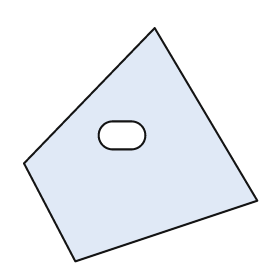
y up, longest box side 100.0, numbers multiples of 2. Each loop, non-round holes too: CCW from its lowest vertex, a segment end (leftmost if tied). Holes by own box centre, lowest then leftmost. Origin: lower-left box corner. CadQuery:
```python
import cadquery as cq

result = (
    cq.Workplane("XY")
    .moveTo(22.0, 0.0)
    .lineTo(100.0, 26.0)
    .lineTo(56.0, 100.0)
    .lineTo(0.0, 42.0)
    .close()
    .moveTo(38.0, 48.0)
    .lineTo(46.0, 48.0)
    .threePointArc((52.0, 54.0), (46.0, 60.0))
    .lineTo(38.0, 60.0)
    .threePointArc((32.0, 54.0), (38.0, 48.0))
    .close()
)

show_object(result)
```